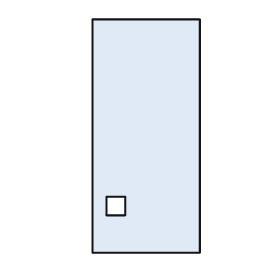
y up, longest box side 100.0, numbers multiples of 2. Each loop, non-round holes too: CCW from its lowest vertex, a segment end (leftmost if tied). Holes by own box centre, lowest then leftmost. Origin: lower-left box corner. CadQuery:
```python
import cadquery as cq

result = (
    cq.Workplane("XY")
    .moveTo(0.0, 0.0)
    .lineTo(46.0, 0.0)
    .lineTo(46.0, 100.0)
    .lineTo(0.0, 100.0)
    .close()
    .moveTo(6.0, 16.0)
    .lineTo(14.0, 16.0)
    .lineTo(14.0, 24.0)
    .lineTo(6.0, 24.0)
    .close()
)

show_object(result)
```